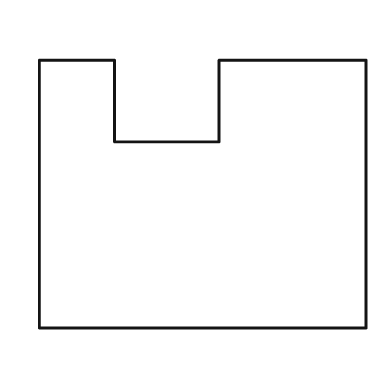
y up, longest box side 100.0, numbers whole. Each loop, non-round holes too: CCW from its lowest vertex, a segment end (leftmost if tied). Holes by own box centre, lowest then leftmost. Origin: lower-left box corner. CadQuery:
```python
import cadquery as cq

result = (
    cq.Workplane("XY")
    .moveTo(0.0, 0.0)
    .lineTo(100.0, 0.0)
    .lineTo(100.0, 82.0)
    .lineTo(55.0, 82.0)
    .lineTo(55.0, 57.0)
    .lineTo(23.0, 57.0)
    .lineTo(23.0, 82.0)
    .lineTo(0.0, 82.0)
    .close()
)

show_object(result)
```